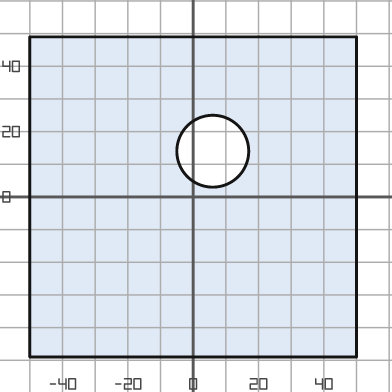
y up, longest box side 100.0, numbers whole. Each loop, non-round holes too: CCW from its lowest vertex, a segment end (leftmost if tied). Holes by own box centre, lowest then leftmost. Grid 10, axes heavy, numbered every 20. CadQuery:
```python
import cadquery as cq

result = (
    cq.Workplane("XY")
    .moveTo(-50.0, -49.0)
    .lineTo(50.0, -49.0)
    .lineTo(50.0, 49.0)
    .lineTo(-50.0, 49.0)
    .close()
    .moveTo(6.0, 14.0)
    .circle(11.0)
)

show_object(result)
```